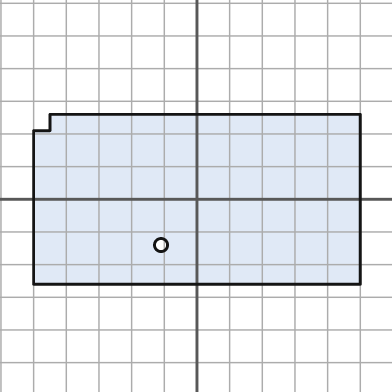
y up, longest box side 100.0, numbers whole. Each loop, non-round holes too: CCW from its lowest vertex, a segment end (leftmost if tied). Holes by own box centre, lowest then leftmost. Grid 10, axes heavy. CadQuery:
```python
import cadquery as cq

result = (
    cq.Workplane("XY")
    .moveTo(-50.0, -26.0)
    .lineTo(50.0, -26.0)
    .lineTo(50.0, 26.0)
    .lineTo(-45.0, 26.0)
    .lineTo(-45.0, 21.0)
    .lineTo(-50.0, 21.0)
    .close()
    .moveTo(-11.0, -14.0)
    .circle(2.0)
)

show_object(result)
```